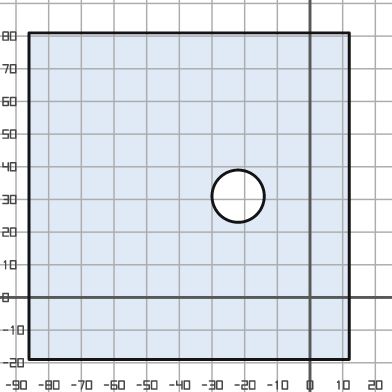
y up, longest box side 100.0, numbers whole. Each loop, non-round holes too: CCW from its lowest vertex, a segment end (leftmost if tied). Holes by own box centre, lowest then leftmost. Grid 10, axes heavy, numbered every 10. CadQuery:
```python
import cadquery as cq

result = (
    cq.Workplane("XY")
    .moveTo(-86.0, -19.0)
    .lineTo(12.0, -19.0)
    .lineTo(12.0, 81.0)
    .lineTo(-86.0, 81.0)
    .close()
    .moveTo(-22.0, 31.0)
    .circle(8.0)
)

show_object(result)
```